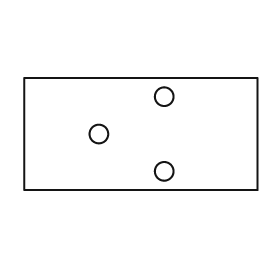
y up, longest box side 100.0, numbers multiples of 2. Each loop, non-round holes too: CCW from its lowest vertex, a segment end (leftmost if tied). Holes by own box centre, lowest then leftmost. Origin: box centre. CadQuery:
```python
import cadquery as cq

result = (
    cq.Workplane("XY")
    .moveTo(-50.0, -24.0)
    .lineTo(50.0, -24.0)
    .lineTo(50.0, 24.0)
    .lineTo(-50.0, 24.0)
    .close()
    .moveTo(10.0, -16.0)
    .circle(4.0)
    .moveTo(-18.0, 0.0)
    .circle(4.0)
    .moveTo(10.0, 16.0)
    .circle(4.0)
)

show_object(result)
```